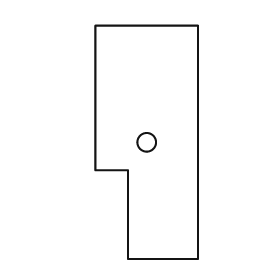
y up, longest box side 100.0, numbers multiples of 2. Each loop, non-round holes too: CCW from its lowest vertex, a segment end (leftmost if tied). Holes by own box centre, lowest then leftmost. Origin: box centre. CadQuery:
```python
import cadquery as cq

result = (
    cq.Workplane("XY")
    .moveTo(-8.0, -50.0)
    .lineTo(22.0, -50.0)
    .lineTo(22.0, 50.0)
    .lineTo(-22.0, 50.0)
    .lineTo(-22.0, -12.0)
    .lineTo(-8.0, -12.0)
    .close()
    .moveTo(0.0, 0.0)
    .circle(4.0)
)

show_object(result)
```